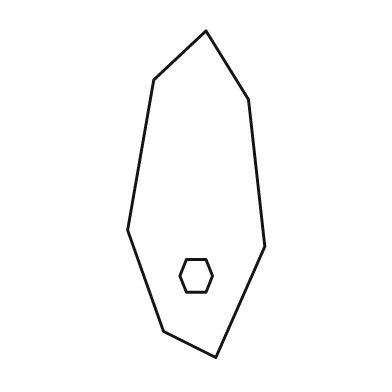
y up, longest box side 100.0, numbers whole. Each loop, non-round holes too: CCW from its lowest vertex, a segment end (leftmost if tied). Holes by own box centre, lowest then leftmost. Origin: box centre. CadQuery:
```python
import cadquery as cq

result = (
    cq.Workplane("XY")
    .moveTo(6.0, -50.0)
    .lineTo(21.0, -16.0)
    .lineTo(16.0, 29.0)
    .lineTo(3.0, 50.0)
    .lineTo(-13.0, 35.0)
    .lineTo(-21.0, -11.0)
    .lineTo(-10.0, -42.0)
    .close()
    .moveTo(-3.0, -30.0)
    .lineTo(3.0, -30.0)
    .lineTo(5.0, -25.0)
    .lineTo(3.0, -20.0)
    .lineTo(-3.0, -20.0)
    .lineTo(-5.0, -25.0)
    .close()
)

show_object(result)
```